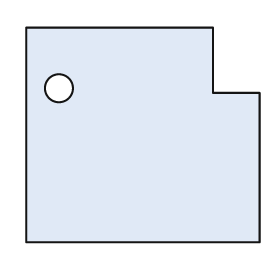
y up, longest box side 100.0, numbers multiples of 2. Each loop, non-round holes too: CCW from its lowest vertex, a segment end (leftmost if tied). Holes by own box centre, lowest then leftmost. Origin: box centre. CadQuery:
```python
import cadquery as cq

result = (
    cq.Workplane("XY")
    .moveTo(-50.0, -46.0)
    .lineTo(50.0, -46.0)
    .lineTo(50.0, 18.0)
    .lineTo(30.0, 18.0)
    .lineTo(30.0, 46.0)
    .lineTo(-50.0, 46.0)
    .close()
    .moveTo(-36.0, 20.0)
    .circle(6.0)
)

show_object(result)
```